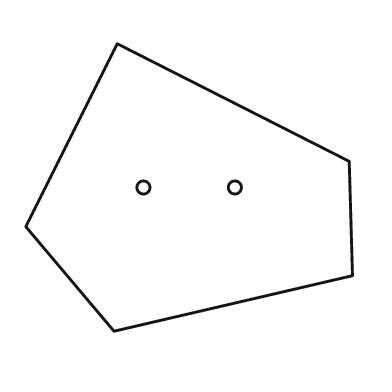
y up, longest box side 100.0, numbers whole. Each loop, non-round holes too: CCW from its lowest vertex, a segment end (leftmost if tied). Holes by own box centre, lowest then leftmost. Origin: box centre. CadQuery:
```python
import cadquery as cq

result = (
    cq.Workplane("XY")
    .moveTo(-23.0, -44.0)
    .lineTo(50.0, -27.0)
    .lineTo(49.0, 8.0)
    .lineTo(-22.0, 44.0)
    .lineTo(-50.0, -12.0)
    .close()
    .moveTo(-14.0, 0.0)
    .circle(2.0)
    .moveTo(14.0, 0.0)
    .circle(2.0)
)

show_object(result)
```